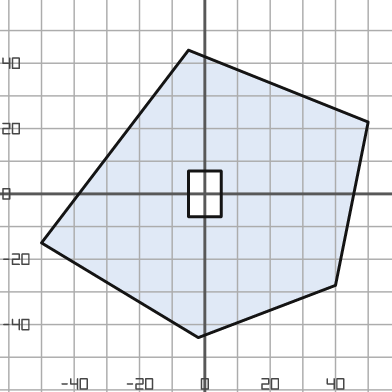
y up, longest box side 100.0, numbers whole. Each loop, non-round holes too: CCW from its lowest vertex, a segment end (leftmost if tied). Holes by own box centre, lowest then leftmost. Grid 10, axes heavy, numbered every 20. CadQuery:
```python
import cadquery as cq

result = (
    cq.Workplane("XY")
    .moveTo(-2.0, -44.0)
    .lineTo(40.0, -28.0)
    .lineTo(50.0, 22.0)
    .lineTo(-5.0, 44.0)
    .lineTo(-50.0, -15.0)
    .close()
    .moveTo(-5.0, -7.0)
    .lineTo(5.0, -7.0)
    .lineTo(5.0, 7.0)
    .lineTo(-5.0, 7.0)
    .close()
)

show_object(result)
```